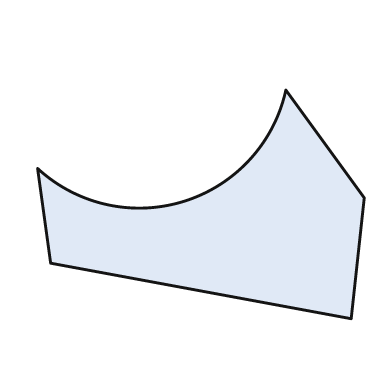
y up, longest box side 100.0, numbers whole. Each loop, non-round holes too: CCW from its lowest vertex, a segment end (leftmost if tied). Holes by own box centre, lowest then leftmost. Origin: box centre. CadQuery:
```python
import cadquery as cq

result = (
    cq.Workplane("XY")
    .moveTo(46.0, -35.0)
    .lineTo(50.0, 2.0)
    .lineTo(26.0, 35.0)
    .threePointArc((-5.0, 1.0), (-50.0, 11.0))
    .lineTo(-46.0, -18.0)
    .close()
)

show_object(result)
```